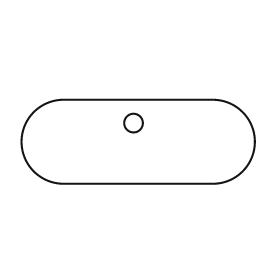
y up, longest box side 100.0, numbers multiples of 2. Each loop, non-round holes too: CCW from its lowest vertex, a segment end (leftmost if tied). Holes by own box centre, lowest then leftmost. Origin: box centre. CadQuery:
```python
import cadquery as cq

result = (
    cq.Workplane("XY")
    .moveTo(-32.0, -18.0)
    .lineTo(32.0, -18.0)
    .threePointArc((50.0, 0.0), (32.0, 18.0))
    .lineTo(-32.0, 18.0)
    .threePointArc((-50.0, 0.0), (-32.0, -18.0))
    .close()
    .moveTo(-2.0, 8.0)
    .circle(4.0)
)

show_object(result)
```